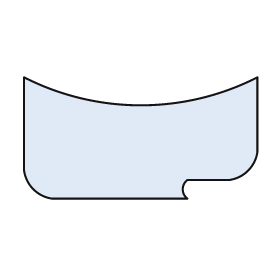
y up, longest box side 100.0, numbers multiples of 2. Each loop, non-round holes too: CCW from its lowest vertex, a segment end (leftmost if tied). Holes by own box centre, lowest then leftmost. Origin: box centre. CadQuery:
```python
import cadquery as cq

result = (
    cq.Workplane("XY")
    .moveTo(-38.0, -26.0)
    .lineTo(20.0, -26.0)
    .threePointArc((18.0, -22.0), (20.0, -18.0))
    .lineTo(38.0, -18.0)
    .threePointArc((46.0, -14.0), (50.0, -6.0))
    .lineTo(50.0, 26.0)
    .threePointArc((0.0, 14.0), (-50.0, 26.0))
    .lineTo(-50.0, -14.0)
    .threePointArc((-46.0, -22.0), (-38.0, -26.0))
    .close()
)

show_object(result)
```